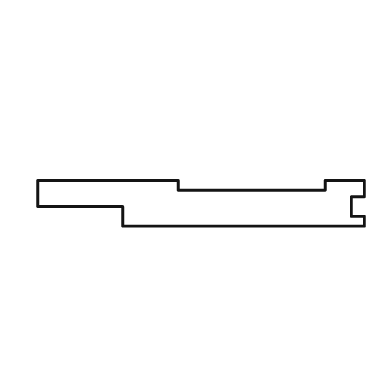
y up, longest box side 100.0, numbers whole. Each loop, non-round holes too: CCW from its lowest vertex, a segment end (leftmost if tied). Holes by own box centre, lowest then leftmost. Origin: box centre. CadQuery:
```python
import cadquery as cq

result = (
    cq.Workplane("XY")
    .moveTo(-24.0, -7.0)
    .lineTo(50.0, -7.0)
    .lineTo(50.0, -4.0)
    .lineTo(46.0, -4.0)
    .lineTo(46.0, 2.0)
    .lineTo(50.0, 2.0)
    .lineTo(50.0, 7.0)
    .lineTo(38.0, 7.0)
    .lineTo(38.0, 4.0)
    .lineTo(-7.0, 4.0)
    .lineTo(-7.0, 7.0)
    .lineTo(-50.0, 7.0)
    .lineTo(-50.0, -1.0)
    .lineTo(-24.0, -1.0)
    .close()
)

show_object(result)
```